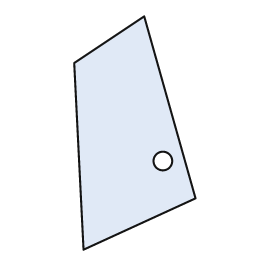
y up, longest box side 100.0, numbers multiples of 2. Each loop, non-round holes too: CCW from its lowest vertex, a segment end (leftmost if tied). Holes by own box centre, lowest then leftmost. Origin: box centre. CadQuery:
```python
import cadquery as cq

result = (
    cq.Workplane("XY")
    .moveTo(-22.0, -50.0)
    .lineTo(26.0, -28.0)
    .lineTo(4.0, 50.0)
    .lineTo(-26.0, 30.0)
    .close()
    .moveTo(12.0, -12.0)
    .circle(4.0)
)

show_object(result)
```